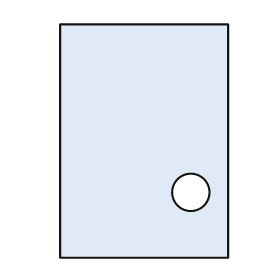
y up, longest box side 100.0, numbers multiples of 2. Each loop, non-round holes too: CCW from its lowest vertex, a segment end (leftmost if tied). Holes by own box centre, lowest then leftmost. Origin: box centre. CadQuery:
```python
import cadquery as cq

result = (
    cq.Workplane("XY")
    .moveTo(-36.0, -50.0)
    .lineTo(36.0, -50.0)
    .lineTo(36.0, 50.0)
    .lineTo(-36.0, 50.0)
    .close()
    .moveTo(20.0, -22.0)
    .circle(8.0)
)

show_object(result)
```